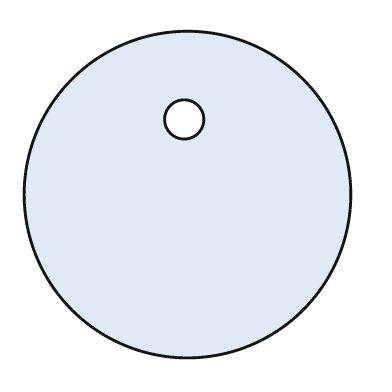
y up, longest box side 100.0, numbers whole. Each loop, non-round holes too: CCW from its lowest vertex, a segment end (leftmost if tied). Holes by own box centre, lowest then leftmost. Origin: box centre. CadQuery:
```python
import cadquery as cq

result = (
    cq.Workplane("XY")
    .moveTo(0.0, 0.0)
    .circle(50.0)
    .moveTo(-1.0, 23.0)
    .circle(6.0)
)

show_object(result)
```